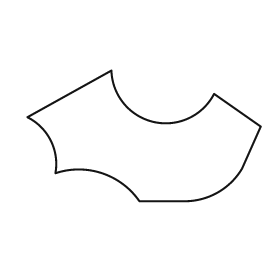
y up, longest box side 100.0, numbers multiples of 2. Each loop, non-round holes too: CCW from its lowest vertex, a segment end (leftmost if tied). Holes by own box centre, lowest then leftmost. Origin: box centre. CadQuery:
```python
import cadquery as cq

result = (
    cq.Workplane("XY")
    .moveTo(-2.0, -28.0)
    .lineTo(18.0, -28.0)
    .threePointArc((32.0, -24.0), (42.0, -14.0))
    .lineTo(50.0, 4.0)
    .lineTo(30.0, 18.0)
    .threePointArc((4.0, 6.0), (-14.0, 28.0))
    .lineTo(-50.0, 8.0)
    .threePointArc((-40.0, -2.0), (-38.0, -16.0))
    .threePointArc((-18.0, -16.0), (-2.0, -28.0))
    .close()
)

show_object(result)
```